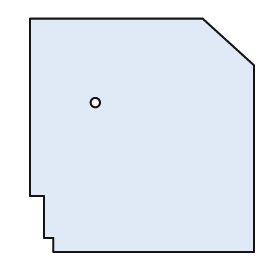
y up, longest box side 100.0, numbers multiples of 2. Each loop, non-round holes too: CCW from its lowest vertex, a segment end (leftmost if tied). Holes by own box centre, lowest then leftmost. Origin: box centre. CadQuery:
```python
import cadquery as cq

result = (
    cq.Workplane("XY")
    .moveTo(-38.0, -50.0)
    .lineTo(48.0, -50.0)
    .lineTo(48.0, 30.0)
    .lineTo(26.0, 50.0)
    .lineTo(-48.0, 50.0)
    .lineTo(-48.0, -26.0)
    .lineTo(-42.0, -26.0)
    .lineTo(-42.0, -44.0)
    .lineTo(-38.0, -44.0)
    .close()
    .moveTo(-20.0, 14.0)
    .circle(2.0)
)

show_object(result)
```